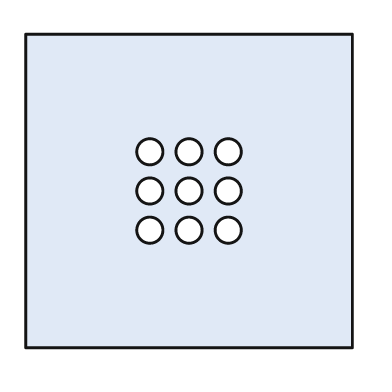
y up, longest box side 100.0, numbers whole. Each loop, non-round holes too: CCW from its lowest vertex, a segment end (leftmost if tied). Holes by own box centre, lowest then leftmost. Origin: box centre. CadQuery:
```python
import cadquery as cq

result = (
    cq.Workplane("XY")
    .moveTo(-50.0, -48.0)
    .lineTo(50.0, -48.0)
    .lineTo(50.0, 48.0)
    .lineTo(-50.0, 48.0)
    .close()
    .moveTo(-12.0, -12.0)
    .circle(4.0)
    .moveTo(0.0, -12.0)
    .circle(4.0)
    .moveTo(12.0, -12.0)
    .circle(4.0)
    .moveTo(-12.0, 0.0)
    .circle(4.0)
    .moveTo(0.0, 0.0)
    .circle(4.0)
    .moveTo(12.0, 0.0)
    .circle(4.0)
    .moveTo(-12.0, 12.0)
    .circle(4.0)
    .moveTo(0.0, 12.0)
    .circle(4.0)
    .moveTo(12.0, 12.0)
    .circle(4.0)
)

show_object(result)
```